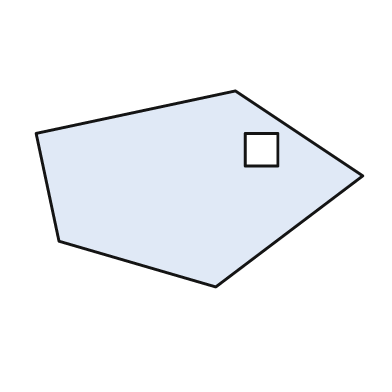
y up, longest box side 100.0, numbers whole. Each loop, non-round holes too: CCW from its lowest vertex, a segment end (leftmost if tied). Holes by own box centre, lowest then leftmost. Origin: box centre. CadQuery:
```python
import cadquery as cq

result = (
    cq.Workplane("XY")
    .moveTo(5.0, -30.0)
    .lineTo(50.0, 4.0)
    .lineTo(11.0, 30.0)
    .lineTo(-50.0, 17.0)
    .lineTo(-43.0, -16.0)
    .close()
    .moveTo(14.0, 7.0)
    .lineTo(24.0, 7.0)
    .lineTo(24.0, 17.0)
    .lineTo(14.0, 17.0)
    .close()
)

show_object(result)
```